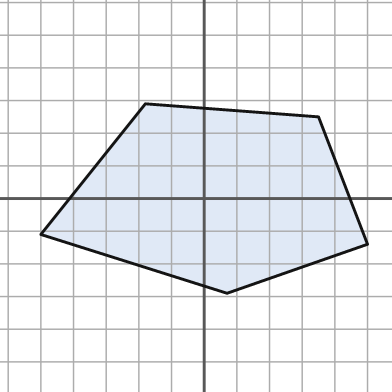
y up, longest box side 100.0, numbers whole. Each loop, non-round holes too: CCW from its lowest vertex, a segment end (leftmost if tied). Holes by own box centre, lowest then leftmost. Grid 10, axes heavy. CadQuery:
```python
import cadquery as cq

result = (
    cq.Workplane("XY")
    .moveTo(7.0, -29.0)
    .lineTo(50.0, -14.0)
    .lineTo(35.0, 25.0)
    .lineTo(-18.0, 29.0)
    .lineTo(-50.0, -11.0)
    .close()
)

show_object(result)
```